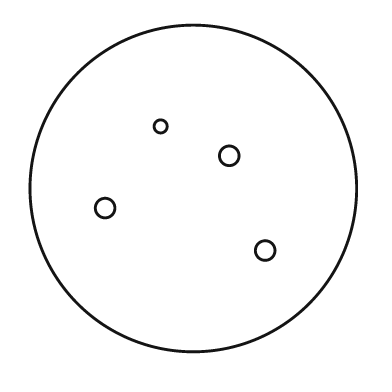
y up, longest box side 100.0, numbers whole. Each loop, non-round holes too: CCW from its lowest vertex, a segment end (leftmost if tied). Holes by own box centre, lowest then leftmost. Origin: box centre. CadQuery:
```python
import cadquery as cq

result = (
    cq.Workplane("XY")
    .moveTo(0.0, 0.0)
    .circle(50.0)
    .moveTo(22.0, -19.0)
    .circle(3.0)
    .moveTo(-27.0, -6.0)
    .circle(3.0)
    .moveTo(11.0, 10.0)
    .circle(3.0)
    .moveTo(-10.0, 19.0)
    .circle(2.0)
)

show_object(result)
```